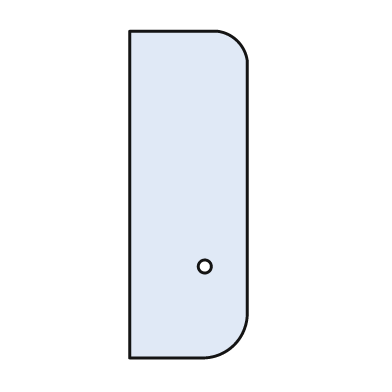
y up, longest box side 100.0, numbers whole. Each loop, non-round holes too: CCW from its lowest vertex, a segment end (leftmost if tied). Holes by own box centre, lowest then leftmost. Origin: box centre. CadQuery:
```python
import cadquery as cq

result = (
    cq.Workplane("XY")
    .moveTo(-18.0, -50.0)
    .lineTo(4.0, -50.0)
    .threePointArc((14.0, -46.0), (18.0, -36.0))
    .lineTo(18.0, 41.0)
    .threePointArc((15.0, 47.0), (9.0, 50.0))
    .lineTo(-18.0, 50.0)
    .close()
    .moveTo(5.0, -22.0)
    .circle(2.0)
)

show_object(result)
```